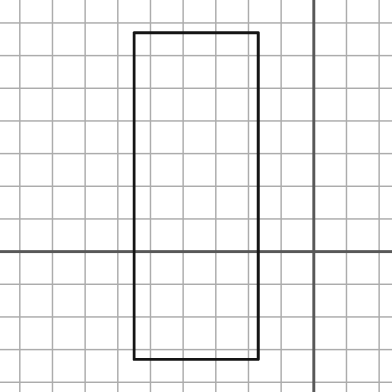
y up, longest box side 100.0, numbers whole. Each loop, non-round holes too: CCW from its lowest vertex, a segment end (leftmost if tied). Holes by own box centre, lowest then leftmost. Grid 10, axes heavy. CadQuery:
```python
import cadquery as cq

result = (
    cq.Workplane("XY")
    .moveTo(-55.0, -33.0)
    .lineTo(-17.0, -33.0)
    .lineTo(-17.0, 67.0)
    .lineTo(-55.0, 67.0)
    .close()
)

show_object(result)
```